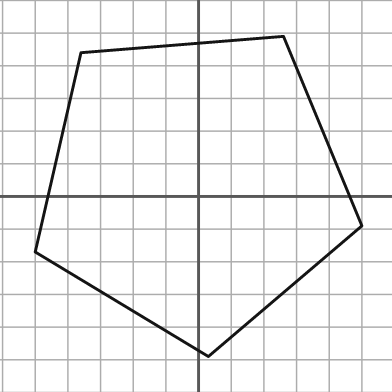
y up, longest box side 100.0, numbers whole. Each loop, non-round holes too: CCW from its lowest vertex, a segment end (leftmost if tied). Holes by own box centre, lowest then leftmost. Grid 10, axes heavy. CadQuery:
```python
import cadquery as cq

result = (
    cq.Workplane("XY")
    .moveTo(3.0, -49.0)
    .lineTo(50.0, -9.0)
    .lineTo(26.0, 49.0)
    .lineTo(-36.0, 44.0)
    .lineTo(-50.0, -17.0)
    .close()
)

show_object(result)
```